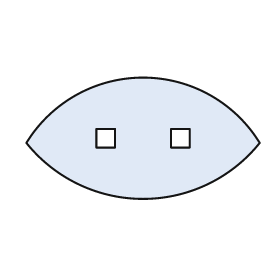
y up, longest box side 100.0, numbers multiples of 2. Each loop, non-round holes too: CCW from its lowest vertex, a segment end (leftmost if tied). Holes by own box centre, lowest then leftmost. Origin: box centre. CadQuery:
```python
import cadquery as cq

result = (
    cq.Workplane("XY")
    .moveTo(-50.0, -2.0)
    .threePointArc((0.0, -26.0), (50.0, -2.0))
    .threePointArc((0.0, 26.0), (-50.0, -2.0))
    .close()
    .moveTo(-20.0, -4.0)
    .lineTo(-12.0, -4.0)
    .lineTo(-12.0, 4.0)
    .lineTo(-20.0, 4.0)
    .close()
    .moveTo(12.0, -4.0)
    .lineTo(20.0, -4.0)
    .lineTo(20.0, 4.0)
    .lineTo(12.0, 4.0)
    .close()
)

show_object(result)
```